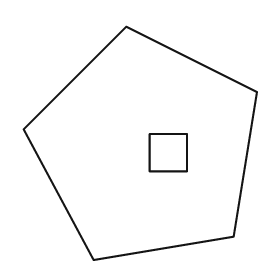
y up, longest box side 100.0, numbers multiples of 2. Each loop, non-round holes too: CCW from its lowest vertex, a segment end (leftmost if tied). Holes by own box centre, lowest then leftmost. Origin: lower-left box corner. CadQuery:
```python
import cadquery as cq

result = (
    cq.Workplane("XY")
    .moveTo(30.0, 0.0)
    .lineTo(90.0, 10.0)
    .lineTo(100.0, 72.0)
    .lineTo(44.0, 100.0)
    .lineTo(0.0, 56.0)
    .close()
    .moveTo(54.0, 38.0)
    .lineTo(70.0, 38.0)
    .lineTo(70.0, 54.0)
    .lineTo(54.0, 54.0)
    .close()
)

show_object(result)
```